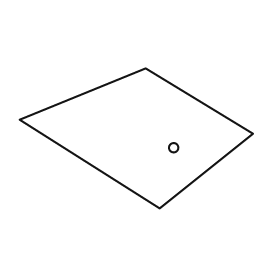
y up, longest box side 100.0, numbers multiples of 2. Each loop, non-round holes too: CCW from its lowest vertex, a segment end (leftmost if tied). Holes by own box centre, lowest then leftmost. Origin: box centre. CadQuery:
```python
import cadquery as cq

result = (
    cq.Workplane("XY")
    .moveTo(10.0, -30.0)
    .lineTo(50.0, 2.0)
    .lineTo(4.0, 30.0)
    .lineTo(-50.0, 8.0)
    .close()
    .moveTo(16.0, -4.0)
    .circle(2.0)
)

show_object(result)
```